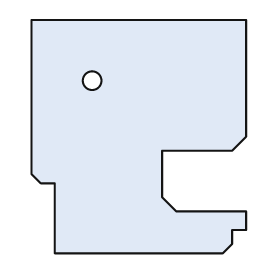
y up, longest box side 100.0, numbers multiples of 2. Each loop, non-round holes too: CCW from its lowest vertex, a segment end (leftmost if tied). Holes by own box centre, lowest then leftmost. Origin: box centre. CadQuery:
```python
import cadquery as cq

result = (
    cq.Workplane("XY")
    .moveTo(-36.0, -50.0)
    .lineTo(36.0, -50.0)
    .lineTo(40.0, -46.0)
    .lineTo(40.0, -40.0)
    .lineTo(46.0, -40.0)
    .lineTo(46.0, -32.0)
    .lineTo(16.0, -32.0)
    .lineTo(10.0, -26.0)
    .lineTo(10.0, -6.0)
    .lineTo(40.0, -6.0)
    .lineTo(46.0, 0.0)
    .lineTo(46.0, 50.0)
    .lineTo(-46.0, 50.0)
    .lineTo(-46.0, -16.0)
    .lineTo(-42.0, -20.0)
    .lineTo(-36.0, -20.0)
    .close()
    .moveTo(-20.0, 24.0)
    .circle(4.0)
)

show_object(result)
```